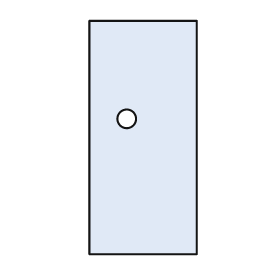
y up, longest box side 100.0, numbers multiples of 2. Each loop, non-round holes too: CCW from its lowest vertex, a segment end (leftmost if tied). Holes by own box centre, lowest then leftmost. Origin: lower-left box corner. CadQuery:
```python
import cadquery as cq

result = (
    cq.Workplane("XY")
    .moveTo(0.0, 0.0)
    .lineTo(46.0, 0.0)
    .lineTo(46.0, 100.0)
    .lineTo(0.0, 100.0)
    .close()
    .moveTo(16.0, 58.0)
    .circle(4.0)
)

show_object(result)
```